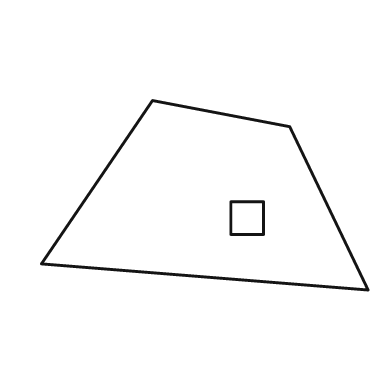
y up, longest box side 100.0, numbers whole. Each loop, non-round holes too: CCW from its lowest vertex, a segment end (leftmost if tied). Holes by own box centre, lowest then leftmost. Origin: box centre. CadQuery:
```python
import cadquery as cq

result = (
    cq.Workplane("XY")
    .moveTo(50.0, -29.0)
    .lineTo(26.0, 21.0)
    .lineTo(-16.0, 29.0)
    .lineTo(-50.0, -21.0)
    .close()
    .moveTo(8.0, -12.0)
    .lineTo(18.0, -12.0)
    .lineTo(18.0, -2.0)
    .lineTo(8.0, -2.0)
    .close()
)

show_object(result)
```